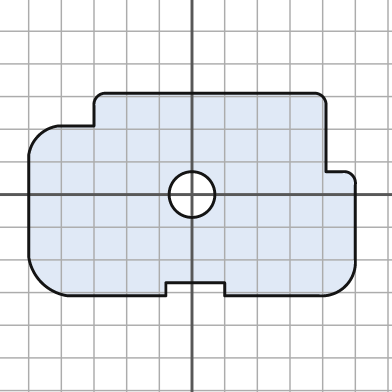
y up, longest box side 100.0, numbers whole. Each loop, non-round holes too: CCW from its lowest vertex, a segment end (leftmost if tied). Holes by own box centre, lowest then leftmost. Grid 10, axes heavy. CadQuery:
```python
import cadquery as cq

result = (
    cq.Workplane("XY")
    .moveTo(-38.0, -31.0)
    .lineTo(-8.0, -31.0)
    .lineTo(-8.0, -27.0)
    .lineTo(10.0, -27.0)
    .lineTo(10.0, -31.0)
    .lineTo(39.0, -31.0)
    .threePointArc((47.0, -28.0), (50.0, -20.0))
    .lineTo(50.0, 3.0)
    .threePointArc((49.0, 6.0), (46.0, 7.0))
    .lineTo(41.0, 7.0)
    .lineTo(41.0, 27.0)
    .threePointArc((40.0, 30.0), (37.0, 31.0))
    .lineTo(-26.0, 31.0)
    .threePointArc((-29.0, 30.0), (-30.0, 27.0))
    .lineTo(-30.0, 21.0)
    .lineTo(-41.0, 21.0)
    .threePointArc((-47.0, 18.0), (-50.0, 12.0))
    .lineTo(-50.0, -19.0)
    .threePointArc((-46.0, -27.0), (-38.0, -31.0))
    .close()
    .moveTo(0.0, 0.0)
    .circle(7.0)
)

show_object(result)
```